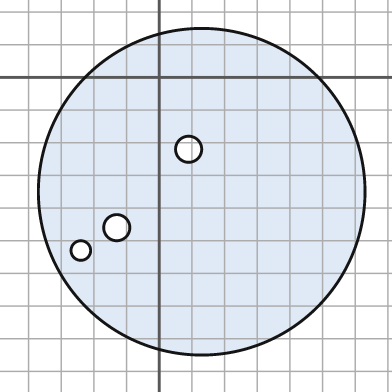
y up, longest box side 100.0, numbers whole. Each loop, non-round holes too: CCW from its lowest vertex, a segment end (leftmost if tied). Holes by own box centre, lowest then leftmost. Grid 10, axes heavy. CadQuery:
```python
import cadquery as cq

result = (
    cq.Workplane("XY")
    .moveTo(13.0, -35.0)
    .circle(50.0)
    .moveTo(-24.0, -53.0)
    .circle(3.0)
    .moveTo(-13.0, -46.0)
    .circle(4.0)
    .moveTo(9.0, -22.0)
    .circle(4.0)
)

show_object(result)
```